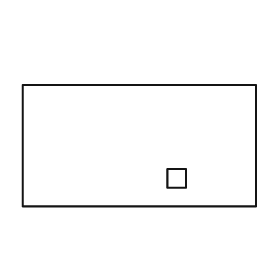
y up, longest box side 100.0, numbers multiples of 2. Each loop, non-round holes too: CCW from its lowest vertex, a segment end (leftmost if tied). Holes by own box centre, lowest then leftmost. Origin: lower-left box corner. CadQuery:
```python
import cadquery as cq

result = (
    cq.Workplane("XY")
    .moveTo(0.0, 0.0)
    .lineTo(100.0, 0.0)
    .lineTo(100.0, 52.0)
    .lineTo(0.0, 52.0)
    .close()
    .moveTo(62.0, 8.0)
    .lineTo(70.0, 8.0)
    .lineTo(70.0, 16.0)
    .lineTo(62.0, 16.0)
    .close()
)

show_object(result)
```